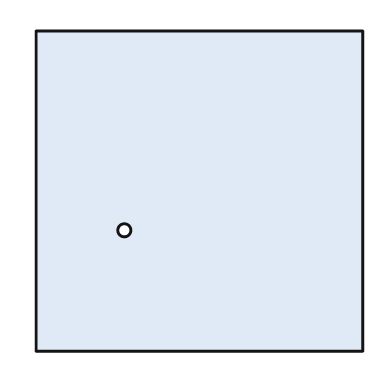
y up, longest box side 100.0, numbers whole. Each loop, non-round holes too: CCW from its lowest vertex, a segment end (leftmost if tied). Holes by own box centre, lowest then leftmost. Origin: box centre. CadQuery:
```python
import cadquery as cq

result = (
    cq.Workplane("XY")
    .moveTo(-50.0, -49.0)
    .lineTo(50.0, -49.0)
    .lineTo(50.0, 49.0)
    .lineTo(-50.0, 49.0)
    .close()
    .moveTo(-23.0, -12.0)
    .circle(2.0)
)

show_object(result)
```